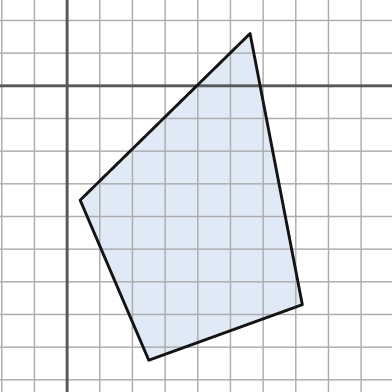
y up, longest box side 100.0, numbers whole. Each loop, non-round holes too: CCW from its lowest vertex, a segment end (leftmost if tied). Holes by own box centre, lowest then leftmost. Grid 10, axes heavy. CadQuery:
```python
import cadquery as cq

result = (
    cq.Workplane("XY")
    .moveTo(25.0, -84.0)
    .lineTo(72.0, -67.0)
    .lineTo(56.0, 16.0)
    .lineTo(4.0, -35.0)
    .close()
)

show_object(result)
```